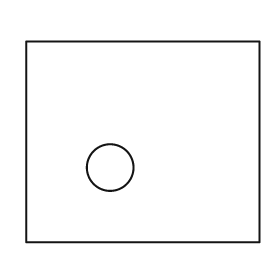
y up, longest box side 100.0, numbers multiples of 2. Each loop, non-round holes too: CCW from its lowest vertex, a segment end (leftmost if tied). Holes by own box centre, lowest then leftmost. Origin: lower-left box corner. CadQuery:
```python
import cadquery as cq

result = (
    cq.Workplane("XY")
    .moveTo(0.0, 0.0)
    .lineTo(100.0, 0.0)
    .lineTo(100.0, 86.0)
    .lineTo(0.0, 86.0)
    .close()
    .moveTo(36.0, 32.0)
    .circle(10.0)
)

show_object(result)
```